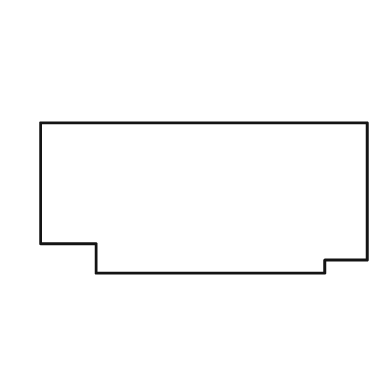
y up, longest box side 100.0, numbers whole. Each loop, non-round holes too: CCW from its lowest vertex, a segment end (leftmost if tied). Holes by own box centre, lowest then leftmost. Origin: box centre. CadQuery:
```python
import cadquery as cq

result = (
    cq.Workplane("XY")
    .moveTo(-33.0, -23.0)
    .lineTo(37.0, -23.0)
    .lineTo(37.0, -19.0)
    .lineTo(50.0, -19.0)
    .lineTo(50.0, 23.0)
    .lineTo(-50.0, 23.0)
    .lineTo(-50.0, -14.0)
    .lineTo(-33.0, -14.0)
    .close()
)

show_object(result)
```